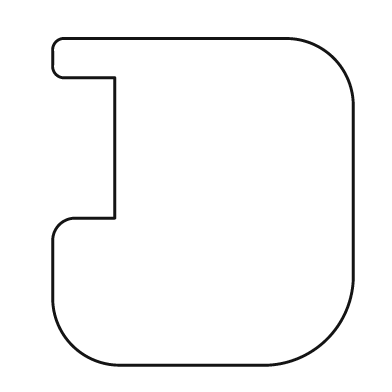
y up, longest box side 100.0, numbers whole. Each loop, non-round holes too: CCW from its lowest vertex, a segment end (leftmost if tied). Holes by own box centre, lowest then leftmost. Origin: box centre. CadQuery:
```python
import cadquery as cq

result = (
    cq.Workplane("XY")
    .moveTo(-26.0, -50.0)
    .lineTo(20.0, -50.0)
    .threePointArc((38.0, -42.0), (46.0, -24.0))
    .lineTo(46.0, 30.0)
    .threePointArc((40.0, 44.0), (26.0, 50.0))
    .lineTo(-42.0, 50.0)
    .threePointArc((-45.0, 49.0), (-46.0, 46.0))
    .lineTo(-46.0, 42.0)
    .threePointArc((-45.0, 39.0), (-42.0, 38.0))
    .lineTo(-27.0, 38.0)
    .lineTo(-27.0, -5.0)
    .lineTo(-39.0, -5.0)
    .threePointArc((-44.0, -7.0), (-46.0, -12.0))
    .lineTo(-46.0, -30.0)
    .threePointArc((-40.0, -44.0), (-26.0, -50.0))
    .close()
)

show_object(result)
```